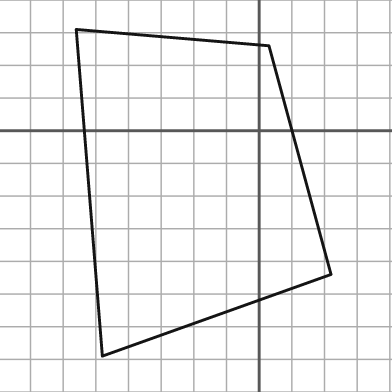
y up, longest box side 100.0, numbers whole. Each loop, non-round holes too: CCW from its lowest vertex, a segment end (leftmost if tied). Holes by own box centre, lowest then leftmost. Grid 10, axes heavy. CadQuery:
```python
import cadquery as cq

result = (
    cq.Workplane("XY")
    .moveTo(-48.0, -69.0)
    .lineTo(22.0, -44.0)
    .lineTo(3.0, 26.0)
    .lineTo(-56.0, 31.0)
    .close()
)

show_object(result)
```